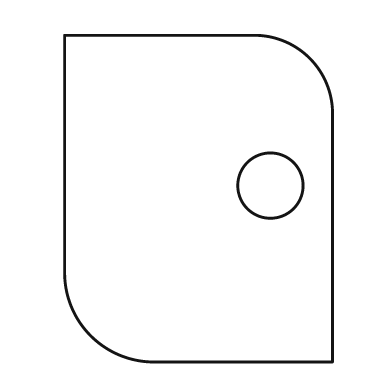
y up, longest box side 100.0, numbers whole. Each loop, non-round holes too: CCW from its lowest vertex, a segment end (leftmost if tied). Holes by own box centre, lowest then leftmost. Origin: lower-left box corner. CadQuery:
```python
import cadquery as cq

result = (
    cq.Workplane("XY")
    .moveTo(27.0, 0.0)
    .lineTo(82.0, 0.0)
    .lineTo(82.0, 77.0)
    .threePointArc((75.0, 93.0), (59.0, 100.0))
    .lineTo(0.0, 100.0)
    .lineTo(0.0, 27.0)
    .threePointArc((8.0, 8.0), (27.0, 0.0))
    .close()
    .moveTo(63.0, 54.0)
    .circle(10.0)
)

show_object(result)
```